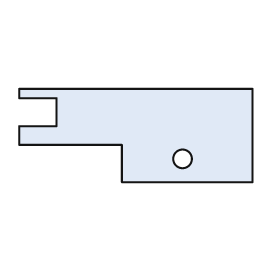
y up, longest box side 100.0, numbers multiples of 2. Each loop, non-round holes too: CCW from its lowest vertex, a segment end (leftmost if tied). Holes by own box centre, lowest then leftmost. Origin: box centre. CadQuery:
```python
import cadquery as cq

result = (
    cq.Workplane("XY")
    .moveTo(-6.0, -20.0)
    .lineTo(50.0, -20.0)
    .lineTo(50.0, 20.0)
    .lineTo(-50.0, 20.0)
    .lineTo(-50.0, 16.0)
    .lineTo(-34.0, 16.0)
    .lineTo(-34.0, 4.0)
    .lineTo(-50.0, 4.0)
    .lineTo(-50.0, -4.0)
    .lineTo(-6.0, -4.0)
    .close()
    .moveTo(20.0, -10.0)
    .circle(4.0)
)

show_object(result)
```